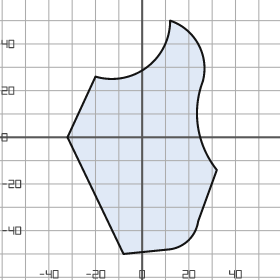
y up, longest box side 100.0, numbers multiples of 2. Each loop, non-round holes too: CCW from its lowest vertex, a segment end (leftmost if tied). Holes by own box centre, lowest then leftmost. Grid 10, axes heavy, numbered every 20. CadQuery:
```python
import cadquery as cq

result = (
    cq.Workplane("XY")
    .moveTo(-8.0, -50.0)
    .lineTo(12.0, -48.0)
    .threePointArc((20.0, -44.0), (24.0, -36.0))
    .lineTo(32.0, -14.0)
    .threePointArc((24.0, 4.0), (26.0, 24.0))
    .threePointArc((24.0, 40.0), (12.0, 50.0))
    .threePointArc((2.0, 30.0), (-20.0, 26.0))
    .lineTo(-32.0, 0.0)
    .close()
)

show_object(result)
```